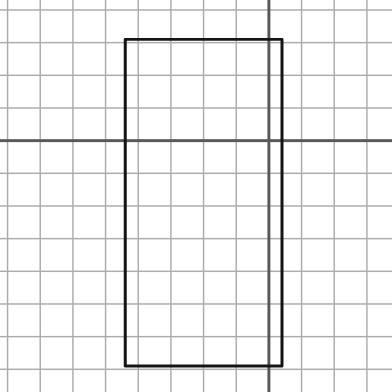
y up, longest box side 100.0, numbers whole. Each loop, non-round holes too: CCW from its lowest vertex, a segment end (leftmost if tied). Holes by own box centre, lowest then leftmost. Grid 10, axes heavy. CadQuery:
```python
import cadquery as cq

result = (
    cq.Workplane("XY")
    .moveTo(-44.0, -69.0)
    .lineTo(4.0, -69.0)
    .lineTo(4.0, 31.0)
    .lineTo(-44.0, 31.0)
    .close()
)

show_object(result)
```